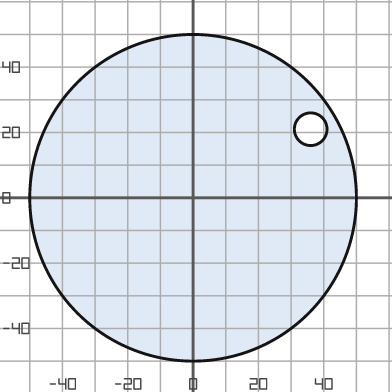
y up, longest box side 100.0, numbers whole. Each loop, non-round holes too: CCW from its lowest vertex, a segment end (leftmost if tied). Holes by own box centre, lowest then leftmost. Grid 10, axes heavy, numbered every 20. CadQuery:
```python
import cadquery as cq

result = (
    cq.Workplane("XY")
    .moveTo(0.0, 0.0)
    .circle(50.0)
    .moveTo(36.0, 21.0)
    .circle(5.0)
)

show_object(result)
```